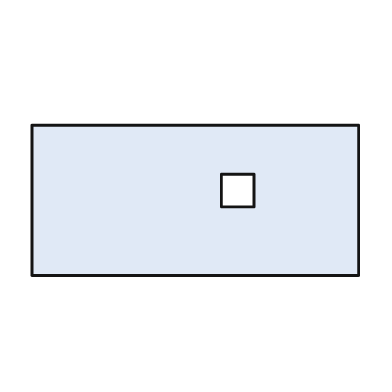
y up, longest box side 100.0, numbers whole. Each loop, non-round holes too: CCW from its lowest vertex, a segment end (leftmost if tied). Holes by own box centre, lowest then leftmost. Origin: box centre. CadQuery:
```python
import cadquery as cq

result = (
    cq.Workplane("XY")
    .moveTo(-50.0, -23.0)
    .lineTo(50.0, -23.0)
    .lineTo(50.0, 23.0)
    .lineTo(-50.0, 23.0)
    .close()
    .moveTo(8.0, -2.0)
    .lineTo(18.0, -2.0)
    .lineTo(18.0, 8.0)
    .lineTo(8.0, 8.0)
    .close()
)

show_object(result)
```